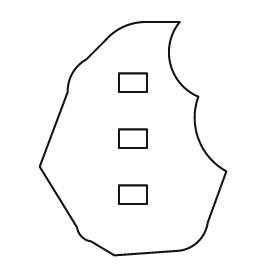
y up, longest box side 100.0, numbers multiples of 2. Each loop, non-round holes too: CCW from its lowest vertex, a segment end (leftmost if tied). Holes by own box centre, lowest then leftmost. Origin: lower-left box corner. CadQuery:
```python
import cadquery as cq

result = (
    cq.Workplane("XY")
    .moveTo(32.0, 0.0)
    .lineTo(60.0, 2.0)
    .threePointArc((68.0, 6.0), (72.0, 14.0))
    .lineTo(80.0, 36.0)
    .threePointArc((68.0, 50.0), (68.0, 68.0))
    .threePointArc((56.0, 82.0), (60.0, 100.0))
    .lineTo(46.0, 100.0)
    .threePointArc((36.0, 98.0), (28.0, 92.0))
    .lineTo(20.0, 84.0)
    .threePointArc((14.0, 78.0), (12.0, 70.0))
    .lineTo(0.0, 38.0)
    .lineTo(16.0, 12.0)
    .threePointArc((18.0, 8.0), (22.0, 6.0))
    .close()
    .moveTo(34.0, 22.0)
    .lineTo(46.0, 22.0)
    .lineTo(46.0, 30.0)
    .lineTo(34.0, 30.0)
    .close()
    .moveTo(34.0, 46.0)
    .lineTo(46.0, 46.0)
    .lineTo(46.0, 54.0)
    .lineTo(34.0, 54.0)
    .close()
    .moveTo(34.0, 70.0)
    .lineTo(46.0, 70.0)
    .lineTo(46.0, 78.0)
    .lineTo(34.0, 78.0)
    .close()
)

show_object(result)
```